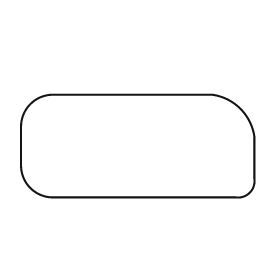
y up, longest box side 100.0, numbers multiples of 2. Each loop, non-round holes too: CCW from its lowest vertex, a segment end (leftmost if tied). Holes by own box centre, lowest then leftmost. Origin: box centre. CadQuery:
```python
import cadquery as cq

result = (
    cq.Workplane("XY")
    .moveTo(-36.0, -22.0)
    .lineTo(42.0, -22.0)
    .threePointArc((48.0, -20.0), (50.0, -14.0))
    .lineTo(50.0, 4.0)
    .threePointArc((44.0, 16.0), (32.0, 22.0))
    .lineTo(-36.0, 22.0)
    .threePointArc((-46.0, 18.0), (-50.0, 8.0))
    .lineTo(-50.0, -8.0)
    .threePointArc((-46.0, -18.0), (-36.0, -22.0))
    .close()
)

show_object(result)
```